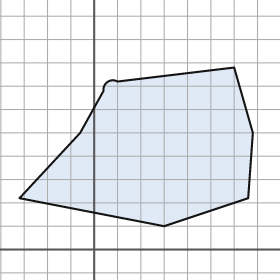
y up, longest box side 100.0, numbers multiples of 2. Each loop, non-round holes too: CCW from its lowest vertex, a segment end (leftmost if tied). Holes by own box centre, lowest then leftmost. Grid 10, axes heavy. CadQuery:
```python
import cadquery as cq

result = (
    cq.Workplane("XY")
    .moveTo(30.0, 10.0)
    .lineTo(66.0, 22.0)
    .lineTo(68.0, 50.0)
    .lineTo(60.0, 78.0)
    .lineTo(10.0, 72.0)
    .threePointArc((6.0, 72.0), (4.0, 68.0))
    .lineTo(-6.0, 50.0)
    .lineTo(-32.0, 22.0)
    .close()
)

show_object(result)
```